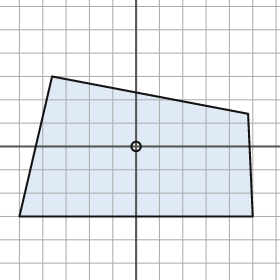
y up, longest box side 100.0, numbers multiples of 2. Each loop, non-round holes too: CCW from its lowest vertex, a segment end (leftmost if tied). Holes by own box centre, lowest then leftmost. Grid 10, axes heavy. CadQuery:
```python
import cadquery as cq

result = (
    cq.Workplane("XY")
    .moveTo(-50.0, -30.0)
    .lineTo(50.0, -30.0)
    .lineTo(48.0, 14.0)
    .lineTo(-36.0, 30.0)
    .close()
    .moveTo(0.0, 0.0)
    .circle(2.0)
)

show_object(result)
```